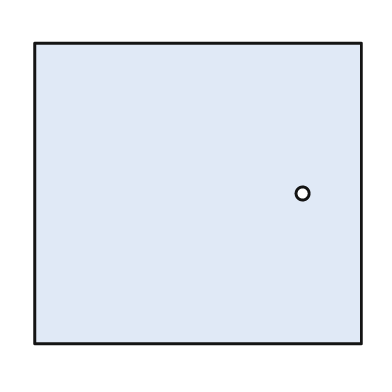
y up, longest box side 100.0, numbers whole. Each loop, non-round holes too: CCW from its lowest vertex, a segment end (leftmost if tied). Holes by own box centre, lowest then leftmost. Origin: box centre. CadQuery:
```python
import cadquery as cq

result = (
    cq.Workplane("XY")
    .moveTo(-50.0, -46.0)
    .lineTo(50.0, -46.0)
    .lineTo(50.0, 46.0)
    .lineTo(-50.0, 46.0)
    .close()
    .moveTo(32.0, 0.0)
    .circle(2.0)
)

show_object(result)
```